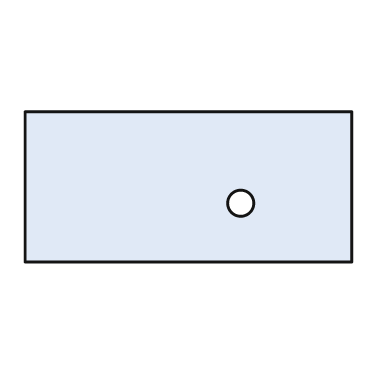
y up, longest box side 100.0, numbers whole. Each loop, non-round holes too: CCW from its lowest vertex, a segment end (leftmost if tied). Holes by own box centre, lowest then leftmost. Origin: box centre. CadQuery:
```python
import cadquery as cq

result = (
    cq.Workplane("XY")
    .moveTo(-50.0, -23.0)
    .lineTo(50.0, -23.0)
    .lineTo(50.0, 23.0)
    .lineTo(-50.0, 23.0)
    .close()
    .moveTo(16.0, -5.0)
    .circle(4.0)
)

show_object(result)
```